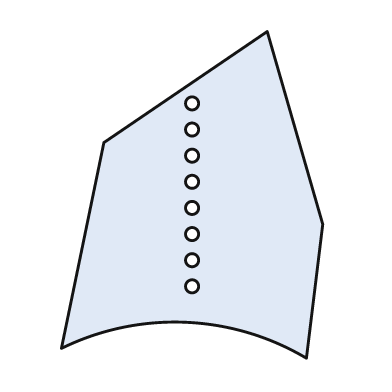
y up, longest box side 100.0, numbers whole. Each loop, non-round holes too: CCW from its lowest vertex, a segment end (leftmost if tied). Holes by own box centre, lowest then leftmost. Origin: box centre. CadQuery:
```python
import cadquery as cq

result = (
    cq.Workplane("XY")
    .moveTo(35.0, -50.0)
    .lineTo(40.0, -9.0)
    .lineTo(23.0, 50.0)
    .lineTo(-27.0, 16.0)
    .lineTo(-40.0, -47.0)
    .threePointArc((-2.0, -39.0), (35.0, -50.0))
    .close()
    .moveTo(0.0, -28.0)
    .circle(2.0)
    .moveTo(0.0, -20.0)
    .circle(2.0)
    .moveTo(0.0, -12.0)
    .circle(2.0)
    .moveTo(0.0, -4.0)
    .circle(2.0)
    .moveTo(0.0, 4.0)
    .circle(2.0)
    .moveTo(0.0, 12.0)
    .circle(2.0)
    .moveTo(0.0, 20.0)
    .circle(2.0)
    .moveTo(0.0, 28.0)
    .circle(2.0)
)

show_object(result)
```